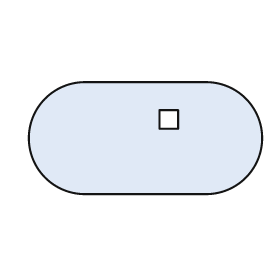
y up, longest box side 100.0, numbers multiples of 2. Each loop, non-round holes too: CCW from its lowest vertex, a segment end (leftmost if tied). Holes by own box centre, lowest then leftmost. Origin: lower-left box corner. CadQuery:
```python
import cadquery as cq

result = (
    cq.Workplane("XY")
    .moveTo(24.0, 0.0)
    .lineTo(76.0, 0.0)
    .threePointArc((100.0, 24.0), (76.0, 48.0))
    .lineTo(24.0, 48.0)
    .threePointArc((0.0, 24.0), (24.0, 0.0))
    .close()
    .moveTo(56.0, 28.0)
    .lineTo(64.0, 28.0)
    .lineTo(64.0, 36.0)
    .lineTo(56.0, 36.0)
    .close()
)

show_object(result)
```